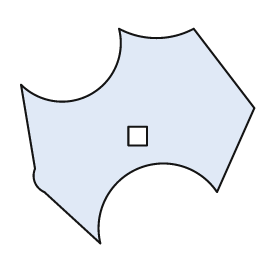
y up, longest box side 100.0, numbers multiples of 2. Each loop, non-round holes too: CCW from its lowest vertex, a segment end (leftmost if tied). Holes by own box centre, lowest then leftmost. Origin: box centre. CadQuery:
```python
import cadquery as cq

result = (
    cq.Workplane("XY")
    .moveTo(-16.0, -46.0)
    .threePointArc((0.0, -14.0), (34.0, -24.0))
    .lineTo(50.0, 12.0)
    .lineTo(24.0, 46.0)
    .threePointArc((8.0, 42.0), (-8.0, 46.0))
    .threePointArc((-20.0, 18.0), (-50.0, 22.0))
    .lineTo(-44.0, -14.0)
    .threePointArc((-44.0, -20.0), (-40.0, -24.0))
    .close()
    .moveTo(-4.0, -4.0)
    .lineTo(4.0, -4.0)
    .lineTo(4.0, 4.0)
    .lineTo(-4.0, 4.0)
    .close()
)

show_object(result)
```